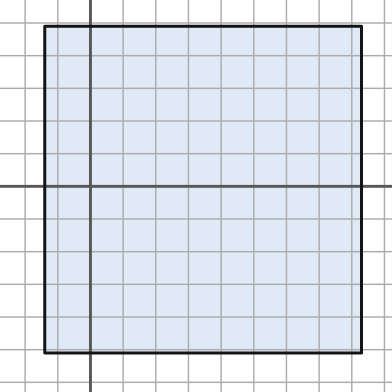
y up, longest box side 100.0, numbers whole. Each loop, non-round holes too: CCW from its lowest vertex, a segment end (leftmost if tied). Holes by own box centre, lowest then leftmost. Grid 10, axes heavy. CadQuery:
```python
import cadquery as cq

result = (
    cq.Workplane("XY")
    .moveTo(-14.0, -51.0)
    .lineTo(83.0, -51.0)
    .lineTo(83.0, 49.0)
    .lineTo(-14.0, 49.0)
    .close()
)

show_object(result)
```